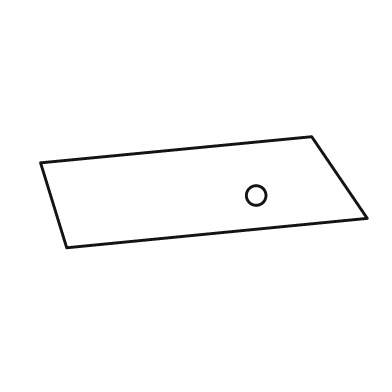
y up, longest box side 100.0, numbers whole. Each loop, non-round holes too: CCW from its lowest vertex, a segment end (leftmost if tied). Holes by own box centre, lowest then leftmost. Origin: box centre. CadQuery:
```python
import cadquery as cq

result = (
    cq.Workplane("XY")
    .moveTo(-42.0, -17.0)
    .lineTo(50.0, -8.0)
    .lineTo(33.0, 17.0)
    .lineTo(-50.0, 9.0)
    .close()
    .moveTo(16.0, -1.0)
    .circle(3.0)
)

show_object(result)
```